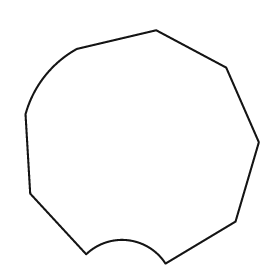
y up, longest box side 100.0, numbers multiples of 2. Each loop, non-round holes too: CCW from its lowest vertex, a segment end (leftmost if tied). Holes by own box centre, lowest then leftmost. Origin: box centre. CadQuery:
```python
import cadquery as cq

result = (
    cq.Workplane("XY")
    .moveTo(10.0, -50.0)
    .lineTo(40.0, -32.0)
    .lineTo(50.0, 2.0)
    .lineTo(36.0, 34.0)
    .lineTo(6.0, 50.0)
    .lineTo(-28.0, 42.0)
    .threePointArc((-42.0, 30.0), (-50.0, 14.0))
    .lineTo(-48.0, -20.0)
    .lineTo(-24.0, -46.0)
    .threePointArc((-6.0, -40.0), (10.0, -50.0))
    .close()
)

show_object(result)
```